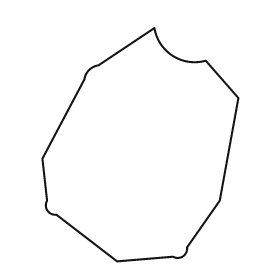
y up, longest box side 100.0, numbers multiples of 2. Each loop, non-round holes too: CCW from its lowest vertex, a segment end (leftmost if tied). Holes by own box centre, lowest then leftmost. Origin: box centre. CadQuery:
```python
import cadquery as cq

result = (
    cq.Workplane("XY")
    .moveTo(-10.0, -50.0)
    .lineTo(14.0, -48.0)
    .threePointArc((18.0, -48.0), (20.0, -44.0))
    .lineTo(34.0, -24.0)
    .lineTo(42.0, 20.0)
    .lineTo(28.0, 36.0)
    .threePointArc((14.0, 38.0), (6.0, 50.0))
    .lineTo(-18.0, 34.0)
    .threePointArc((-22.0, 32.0), (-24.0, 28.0))
    .lineTo(-42.0, -6.0)
    .lineTo(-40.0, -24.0)
    .threePointArc((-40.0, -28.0), (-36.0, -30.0))
    .close()
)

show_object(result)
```